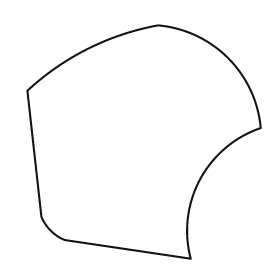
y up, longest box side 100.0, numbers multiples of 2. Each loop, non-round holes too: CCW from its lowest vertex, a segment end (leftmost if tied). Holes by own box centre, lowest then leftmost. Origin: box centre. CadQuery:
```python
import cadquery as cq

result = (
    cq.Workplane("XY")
    .moveTo(20.0, -50.0)
    .threePointArc((24.0, -16.0), (50.0, 6.0))
    .threePointArc((36.0, 36.0), (6.0, 50.0))
    .threePointArc((-24.0, 40.0), (-50.0, 22.0))
    .lineTo(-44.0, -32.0)
    .threePointArc((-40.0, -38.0), (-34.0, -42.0))
    .close()
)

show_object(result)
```